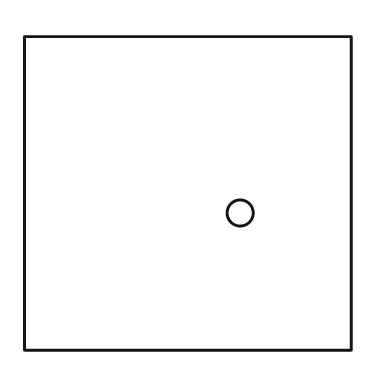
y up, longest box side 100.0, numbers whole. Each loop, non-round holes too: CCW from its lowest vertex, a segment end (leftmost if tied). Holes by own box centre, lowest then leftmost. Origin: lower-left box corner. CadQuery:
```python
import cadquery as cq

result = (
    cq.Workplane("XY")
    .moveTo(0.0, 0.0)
    .lineTo(100.0, 0.0)
    .lineTo(100.0, 96.0)
    .lineTo(0.0, 96.0)
    .close()
    .moveTo(66.0, 42.0)
    .circle(4.0)
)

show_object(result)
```